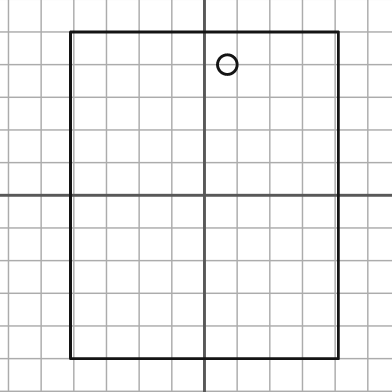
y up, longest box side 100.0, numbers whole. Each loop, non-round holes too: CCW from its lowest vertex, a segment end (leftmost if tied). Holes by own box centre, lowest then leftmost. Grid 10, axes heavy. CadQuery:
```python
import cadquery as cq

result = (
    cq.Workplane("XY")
    .moveTo(-41.0, -50.0)
    .lineTo(41.0, -50.0)
    .lineTo(41.0, 50.0)
    .lineTo(-41.0, 50.0)
    .close()
    .moveTo(7.0, 40.0)
    .circle(3.0)
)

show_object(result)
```